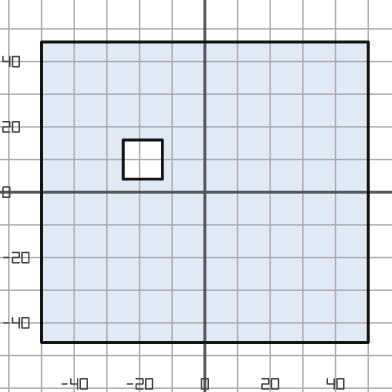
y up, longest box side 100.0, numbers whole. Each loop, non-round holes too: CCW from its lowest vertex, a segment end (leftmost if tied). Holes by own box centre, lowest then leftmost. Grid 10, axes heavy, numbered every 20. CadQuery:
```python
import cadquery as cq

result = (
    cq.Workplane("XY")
    .moveTo(-50.0, -46.0)
    .lineTo(50.0, -46.0)
    .lineTo(50.0, 46.0)
    .lineTo(-50.0, 46.0)
    .close()
    .moveTo(-25.0, 4.0)
    .lineTo(-13.0, 4.0)
    .lineTo(-13.0, 16.0)
    .lineTo(-25.0, 16.0)
    .close()
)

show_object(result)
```